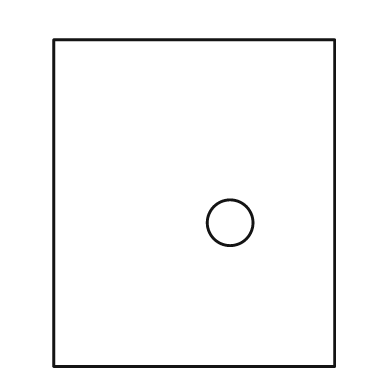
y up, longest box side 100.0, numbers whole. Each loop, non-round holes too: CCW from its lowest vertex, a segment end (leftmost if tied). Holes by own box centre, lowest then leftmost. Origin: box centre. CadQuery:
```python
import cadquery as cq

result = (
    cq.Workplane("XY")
    .moveTo(-43.0, -50.0)
    .lineTo(43.0, -50.0)
    .lineTo(43.0, 50.0)
    .lineTo(-43.0, 50.0)
    .close()
    .moveTo(11.0, -6.0)
    .circle(7.0)
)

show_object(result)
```